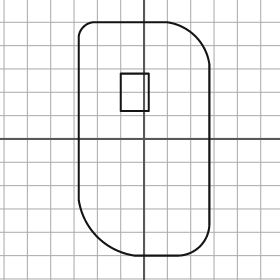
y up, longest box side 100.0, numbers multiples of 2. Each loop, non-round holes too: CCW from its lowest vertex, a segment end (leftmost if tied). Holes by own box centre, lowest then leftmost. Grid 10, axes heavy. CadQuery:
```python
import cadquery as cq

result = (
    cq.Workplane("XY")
    .moveTo(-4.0, -50.0)
    .lineTo(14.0, -50.0)
    .threePointArc((24.0, -46.0), (28.0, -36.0))
    .lineTo(28.0, 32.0)
    .threePointArc((22.0, 44.0), (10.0, 50.0))
    .lineTo(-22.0, 50.0)
    .threePointArc((-26.0, 48.0), (-28.0, 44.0))
    .lineTo(-28.0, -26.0)
    .threePointArc((-20.0, -42.0), (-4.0, -50.0))
    .close()
    .moveTo(-10.0, 12.0)
    .lineTo(2.0, 12.0)
    .lineTo(2.0, 28.0)
    .lineTo(-10.0, 28.0)
    .close()
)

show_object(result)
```